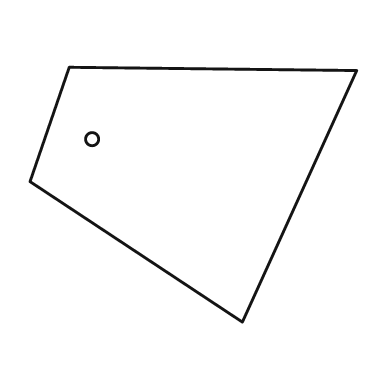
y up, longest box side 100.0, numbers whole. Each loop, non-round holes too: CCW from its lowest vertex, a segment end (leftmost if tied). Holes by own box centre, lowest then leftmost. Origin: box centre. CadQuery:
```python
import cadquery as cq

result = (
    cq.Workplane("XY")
    .moveTo(15.0, -39.0)
    .lineTo(50.0, 38.0)
    .lineTo(-38.0, 39.0)
    .lineTo(-50.0, 4.0)
    .close()
    .moveTo(-31.0, 17.0)
    .circle(2.0)
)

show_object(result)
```